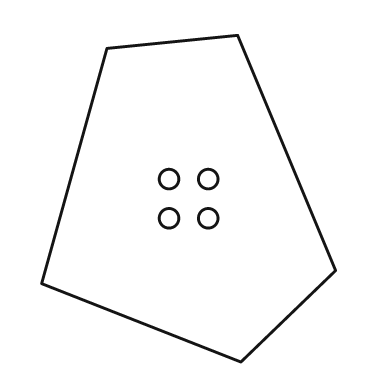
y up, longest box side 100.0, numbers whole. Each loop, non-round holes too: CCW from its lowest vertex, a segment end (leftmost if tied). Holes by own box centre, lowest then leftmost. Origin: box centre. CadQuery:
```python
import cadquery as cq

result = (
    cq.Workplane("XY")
    .moveTo(16.0, -50.0)
    .lineTo(45.0, -22.0)
    .lineTo(15.0, 50.0)
    .lineTo(-25.0, 46.0)
    .lineTo(-45.0, -26.0)
    .close()
    .moveTo(-6.0, -6.0)
    .circle(3.0)
    .moveTo(6.0, -6.0)
    .circle(3.0)
    .moveTo(-6.0, 6.0)
    .circle(3.0)
    .moveTo(6.0, 6.0)
    .circle(3.0)
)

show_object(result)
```